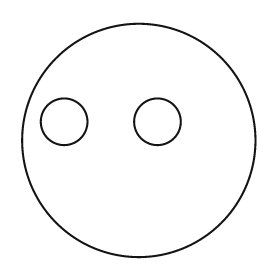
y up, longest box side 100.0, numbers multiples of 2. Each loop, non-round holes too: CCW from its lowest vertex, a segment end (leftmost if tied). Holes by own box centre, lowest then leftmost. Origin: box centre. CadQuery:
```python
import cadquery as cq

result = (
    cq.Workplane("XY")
    .moveTo(0.0, 0.0)
    .circle(50.0)
    .moveTo(-32.0, 8.0)
    .circle(10.0)
    .moveTo(8.0, 8.0)
    .circle(10.0)
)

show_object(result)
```